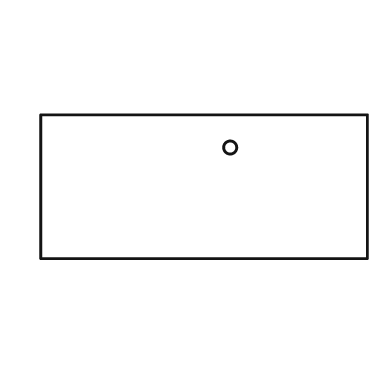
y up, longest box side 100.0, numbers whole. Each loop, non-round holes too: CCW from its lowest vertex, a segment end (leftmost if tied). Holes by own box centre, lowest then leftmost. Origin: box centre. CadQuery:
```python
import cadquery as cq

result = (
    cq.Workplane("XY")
    .moveTo(-50.0, -22.0)
    .lineTo(50.0, -22.0)
    .lineTo(50.0, 22.0)
    .lineTo(-50.0, 22.0)
    .close()
    .moveTo(8.0, 12.0)
    .circle(2.0)
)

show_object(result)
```